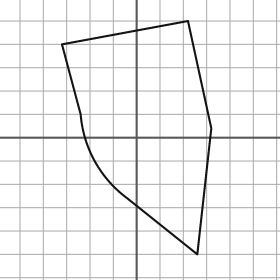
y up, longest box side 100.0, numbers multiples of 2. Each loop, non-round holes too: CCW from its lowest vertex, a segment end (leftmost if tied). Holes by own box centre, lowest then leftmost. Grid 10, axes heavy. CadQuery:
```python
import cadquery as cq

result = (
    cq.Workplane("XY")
    .moveTo(26.0, -50.0)
    .lineTo(32.0, 4.0)
    .lineTo(22.0, 50.0)
    .lineTo(-32.0, 40.0)
    .lineTo(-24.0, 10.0)
    .threePointArc((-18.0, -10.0), (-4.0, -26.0))
    .close()
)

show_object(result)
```